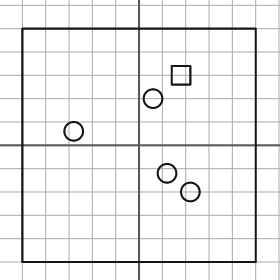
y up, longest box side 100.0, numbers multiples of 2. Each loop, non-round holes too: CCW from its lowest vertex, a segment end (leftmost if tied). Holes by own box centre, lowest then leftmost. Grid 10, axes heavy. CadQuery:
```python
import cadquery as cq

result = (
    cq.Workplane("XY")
    .moveTo(-50.0, -50.0)
    .lineTo(50.0, -50.0)
    .lineTo(50.0, 50.0)
    .lineTo(-50.0, 50.0)
    .close()
    .moveTo(22.0, -20.0)
    .circle(4.0)
    .moveTo(12.0, -12.0)
    .circle(4.0)
    .moveTo(-28.0, 6.0)
    .circle(4.0)
    .moveTo(6.0, 20.0)
    .circle(4.0)
    .moveTo(14.0, 26.0)
    .lineTo(22.0, 26.0)
    .lineTo(22.0, 34.0)
    .lineTo(14.0, 34.0)
    .close()
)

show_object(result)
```